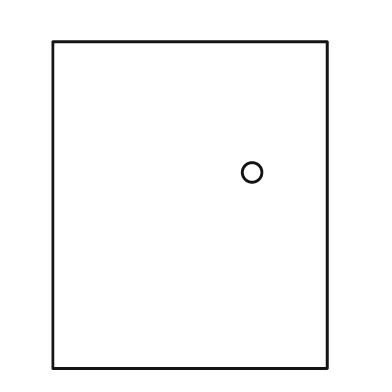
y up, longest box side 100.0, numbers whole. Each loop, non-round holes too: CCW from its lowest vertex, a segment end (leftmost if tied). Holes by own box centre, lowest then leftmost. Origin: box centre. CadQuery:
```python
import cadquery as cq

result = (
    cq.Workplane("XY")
    .moveTo(-42.0, -50.0)
    .lineTo(42.0, -50.0)
    .lineTo(42.0, 50.0)
    .lineTo(-42.0, 50.0)
    .close()
    .moveTo(19.0, 10.0)
    .circle(3.0)
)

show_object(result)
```